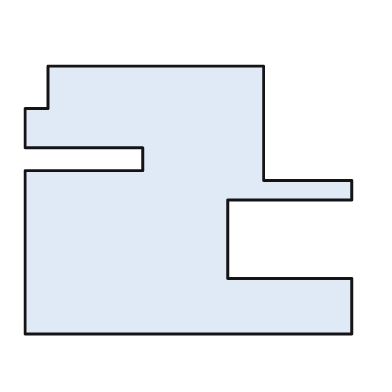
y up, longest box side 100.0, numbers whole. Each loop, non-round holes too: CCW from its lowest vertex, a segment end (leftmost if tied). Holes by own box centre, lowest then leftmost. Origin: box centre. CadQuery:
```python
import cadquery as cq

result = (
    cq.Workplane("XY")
    .moveTo(-50.0, -41.0)
    .lineTo(50.0, -41.0)
    .lineTo(50.0, -24.0)
    .lineTo(12.0, -24.0)
    .lineTo(12.0, 0.0)
    .lineTo(50.0, 0.0)
    .lineTo(50.0, 6.0)
    .lineTo(23.0, 6.0)
    .lineTo(23.0, 41.0)
    .lineTo(-43.0, 41.0)
    .lineTo(-43.0, 28.0)
    .lineTo(-50.0, 28.0)
    .lineTo(-50.0, 16.0)
    .lineTo(-14.0, 16.0)
    .lineTo(-14.0, 9.0)
    .lineTo(-50.0, 9.0)
    .close()
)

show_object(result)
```